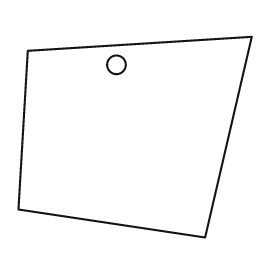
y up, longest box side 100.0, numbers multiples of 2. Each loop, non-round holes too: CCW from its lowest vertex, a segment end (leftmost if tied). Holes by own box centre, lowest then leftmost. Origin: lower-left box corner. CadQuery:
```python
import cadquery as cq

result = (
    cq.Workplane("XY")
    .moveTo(80.0, 0.0)
    .lineTo(100.0, 86.0)
    .lineTo(4.0, 80.0)
    .lineTo(0.0, 12.0)
    .close()
    .moveTo(42.0, 74.0)
    .circle(4.0)
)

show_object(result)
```